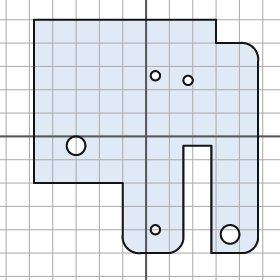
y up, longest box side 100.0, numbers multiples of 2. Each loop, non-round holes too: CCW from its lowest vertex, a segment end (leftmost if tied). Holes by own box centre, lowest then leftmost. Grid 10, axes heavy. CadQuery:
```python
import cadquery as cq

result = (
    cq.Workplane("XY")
    .moveTo(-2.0, -50.0)
    .lineTo(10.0, -50.0)
    .threePointArc((14.0, -48.0), (16.0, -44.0))
    .lineTo(16.0, -4.0)
    .lineTo(28.0, -4.0)
    .lineTo(28.0, -50.0)
    .lineTo(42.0, -50.0)
    .threePointArc((46.0, -48.0), (48.0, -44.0))
    .lineTo(48.0, 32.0)
    .threePointArc((46.0, 38.0), (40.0, 40.0))
    .lineTo(30.0, 40.0)
    .lineTo(30.0, 50.0)
    .lineTo(-48.0, 50.0)
    .lineTo(-48.0, -20.0)
    .lineTo(-10.0, -20.0)
    .lineTo(-10.0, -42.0)
    .threePointArc((-8.0, -48.0), (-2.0, -50.0))
    .close()
    .moveTo(36.0, -42.0)
    .circle(4.0)
    .moveTo(4.0, -40.0)
    .circle(2.0)
    .moveTo(-30.0, -4.0)
    .circle(4.0)
    .moveTo(18.0, 24.0)
    .circle(2.0)
    .moveTo(4.0, 26.0)
    .circle(2.0)
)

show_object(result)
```